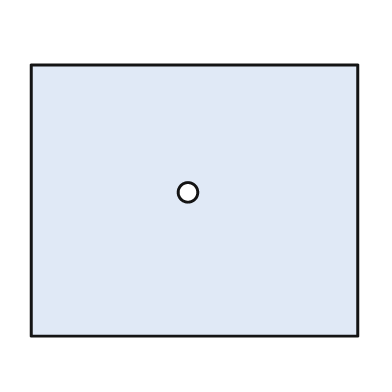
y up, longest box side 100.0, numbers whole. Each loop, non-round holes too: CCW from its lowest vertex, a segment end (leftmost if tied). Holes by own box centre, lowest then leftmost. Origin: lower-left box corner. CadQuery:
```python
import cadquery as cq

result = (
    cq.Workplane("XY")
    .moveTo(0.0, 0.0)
    .lineTo(100.0, 0.0)
    .lineTo(100.0, 83.0)
    .lineTo(0.0, 83.0)
    .close()
    .moveTo(48.0, 44.0)
    .circle(3.0)
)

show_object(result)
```